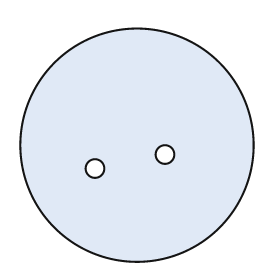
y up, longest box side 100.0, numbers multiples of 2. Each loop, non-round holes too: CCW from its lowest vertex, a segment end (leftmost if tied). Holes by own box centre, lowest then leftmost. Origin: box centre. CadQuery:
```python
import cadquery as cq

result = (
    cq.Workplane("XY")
    .moveTo(0.0, 0.0)
    .circle(50.0)
    .moveTo(-18.0, -10.0)
    .circle(4.0)
    .moveTo(12.0, -4.0)
    .circle(4.0)
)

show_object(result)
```